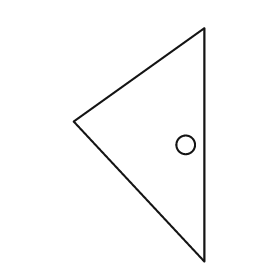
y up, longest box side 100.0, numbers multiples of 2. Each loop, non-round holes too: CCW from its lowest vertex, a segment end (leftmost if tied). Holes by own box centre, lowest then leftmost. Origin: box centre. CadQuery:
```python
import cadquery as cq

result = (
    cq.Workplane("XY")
    .moveTo(28.0, -50.0)
    .lineTo(28.0, 50.0)
    .lineTo(-28.0, 10.0)
    .close()
    .moveTo(20.0, 0.0)
    .circle(4.0)
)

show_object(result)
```